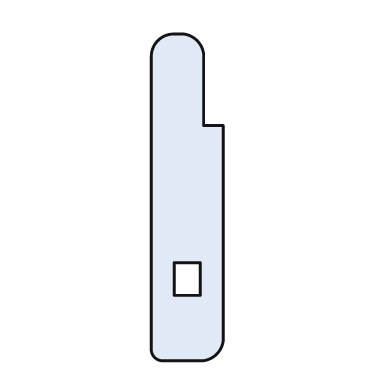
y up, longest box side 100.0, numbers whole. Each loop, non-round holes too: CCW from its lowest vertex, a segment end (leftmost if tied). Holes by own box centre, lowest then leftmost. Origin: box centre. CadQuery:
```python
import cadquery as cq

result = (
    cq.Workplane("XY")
    .moveTo(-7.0, -50.0)
    .lineTo(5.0, -50.0)
    .threePointArc((9.0, -48.0), (11.0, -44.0))
    .lineTo(11.0, 22.0)
    .lineTo(5.0, 22.0)
    .lineTo(5.0, 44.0)
    .threePointArc((3.0, 48.0), (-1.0, 50.0))
    .lineTo(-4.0, 50.0)
    .threePointArc((-9.0, 48.0), (-11.0, 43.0))
    .lineTo(-11.0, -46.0)
    .threePointArc((-10.0, -49.0), (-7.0, -50.0))
    .close()
    .moveTo(-4.0, -30.0)
    .lineTo(4.0, -30.0)
    .lineTo(4.0, -20.0)
    .lineTo(-4.0, -20.0)
    .close()
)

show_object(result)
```